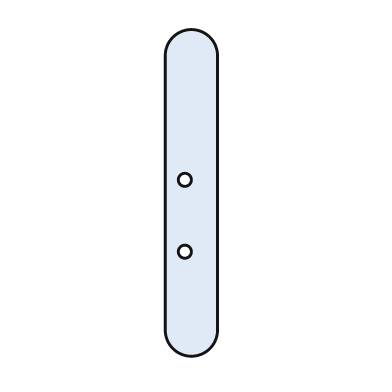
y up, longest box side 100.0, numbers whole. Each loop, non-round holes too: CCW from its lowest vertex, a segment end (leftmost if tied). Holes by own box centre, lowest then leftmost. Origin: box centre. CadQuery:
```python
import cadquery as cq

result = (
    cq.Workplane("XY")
    .moveTo(-8.0, -42.0)
    .threePointArc((0.0, -50.0), (8.0, -42.0))
    .lineTo(8.0, 42.0)
    .threePointArc((0.0, 50.0), (-8.0, 42.0))
    .close()
    .moveTo(-2.0, -18.0)
    .circle(2.0)
    .moveTo(-2.0, 4.0)
    .circle(2.0)
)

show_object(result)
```